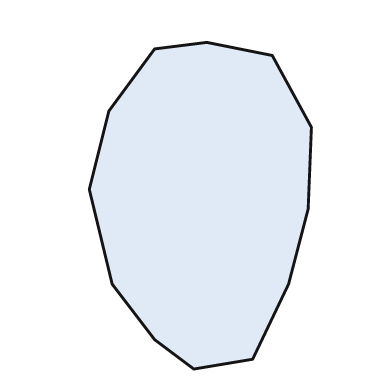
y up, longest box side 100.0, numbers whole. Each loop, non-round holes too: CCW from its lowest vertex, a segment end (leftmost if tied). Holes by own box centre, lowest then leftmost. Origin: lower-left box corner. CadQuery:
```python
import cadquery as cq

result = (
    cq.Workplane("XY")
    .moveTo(32.0, 0.0)
    .lineTo(50.0, 3.0)
    .lineTo(61.0, 26.0)
    .lineTo(67.0, 49.0)
    .lineTo(68.0, 74.0)
    .lineTo(56.0, 96.0)
    .lineTo(36.0, 100.0)
    .lineTo(20.0, 98.0)
    .lineTo(6.0, 79.0)
    .lineTo(0.0, 55.0)
    .lineTo(7.0, 26.0)
    .lineTo(20.0, 9.0)
    .close()
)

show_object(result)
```